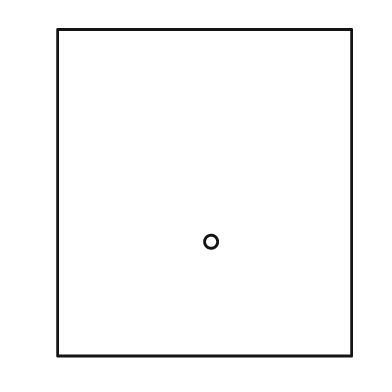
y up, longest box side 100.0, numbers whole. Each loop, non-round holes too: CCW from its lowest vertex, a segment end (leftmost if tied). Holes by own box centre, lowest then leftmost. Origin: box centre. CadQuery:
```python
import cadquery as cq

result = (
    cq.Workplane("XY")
    .moveTo(-45.0, -50.0)
    .lineTo(45.0, -50.0)
    .lineTo(45.0, 50.0)
    .lineTo(-45.0, 50.0)
    .close()
    .moveTo(2.0, -15.0)
    .circle(2.0)
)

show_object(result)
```